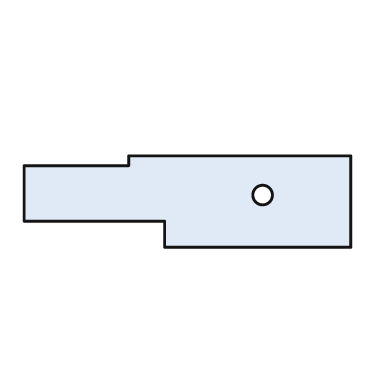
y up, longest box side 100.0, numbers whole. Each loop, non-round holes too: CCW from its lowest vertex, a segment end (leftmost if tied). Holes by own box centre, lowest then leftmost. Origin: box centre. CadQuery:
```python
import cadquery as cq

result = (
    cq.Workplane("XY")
    .moveTo(-7.0, -14.0)
    .lineTo(50.0, -14.0)
    .lineTo(50.0, 14.0)
    .lineTo(-18.0, 14.0)
    .lineTo(-18.0, 11.0)
    .lineTo(-50.0, 11.0)
    .lineTo(-50.0, -6.0)
    .lineTo(-7.0, -6.0)
    .close()
    .moveTo(23.0, 2.0)
    .circle(3.0)
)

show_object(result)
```